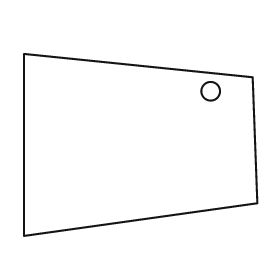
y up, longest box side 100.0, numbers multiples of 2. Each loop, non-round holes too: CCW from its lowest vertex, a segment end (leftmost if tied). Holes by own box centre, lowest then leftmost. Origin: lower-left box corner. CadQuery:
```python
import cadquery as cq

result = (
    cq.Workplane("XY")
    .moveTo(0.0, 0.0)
    .lineTo(100.0, 14.0)
    .lineTo(98.0, 68.0)
    .lineTo(0.0, 78.0)
    .close()
    .moveTo(80.0, 62.0)
    .circle(4.0)
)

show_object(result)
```